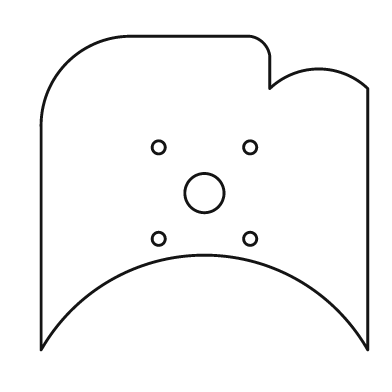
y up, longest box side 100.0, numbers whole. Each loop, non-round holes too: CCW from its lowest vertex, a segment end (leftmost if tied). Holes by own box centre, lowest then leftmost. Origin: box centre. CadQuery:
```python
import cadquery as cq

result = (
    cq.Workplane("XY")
    .moveTo(-50.0, -48.0)
    .threePointArc((0.0, -19.0), (50.0, -48.0))
    .lineTo(50.0, 32.0)
    .threePointArc((35.0, 38.0), (20.0, 32.0))
    .lineTo(20.0, 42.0)
    .threePointArc((18.0, 46.0), (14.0, 48.0))
    .lineTo(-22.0, 48.0)
    .threePointArc((-42.0, 40.0), (-50.0, 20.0))
    .close()
    .moveTo(-14.0, -14.0)
    .circle(2.0)
    .moveTo(14.0, -14.0)
    .circle(2.0)
    .moveTo(0.0, 0.0)
    .circle(6.0)
    .moveTo(-14.0, 14.0)
    .circle(2.0)
    .moveTo(14.0, 14.0)
    .circle(2.0)
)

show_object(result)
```